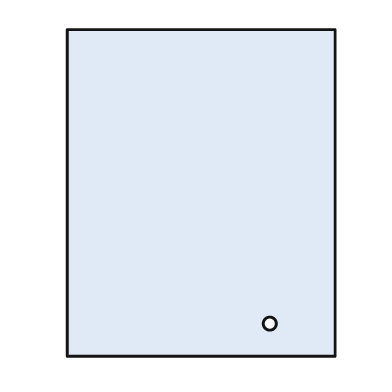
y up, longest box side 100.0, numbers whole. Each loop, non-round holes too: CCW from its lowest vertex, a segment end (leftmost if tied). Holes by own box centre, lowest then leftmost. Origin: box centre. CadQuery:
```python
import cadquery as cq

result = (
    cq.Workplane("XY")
    .moveTo(-41.0, -50.0)
    .lineTo(41.0, -50.0)
    .lineTo(41.0, 50.0)
    .lineTo(-41.0, 50.0)
    .close()
    .moveTo(21.0, -40.0)
    .circle(2.0)
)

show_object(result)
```